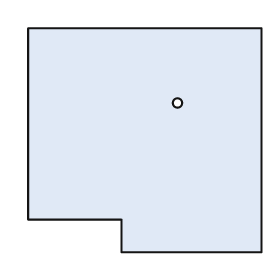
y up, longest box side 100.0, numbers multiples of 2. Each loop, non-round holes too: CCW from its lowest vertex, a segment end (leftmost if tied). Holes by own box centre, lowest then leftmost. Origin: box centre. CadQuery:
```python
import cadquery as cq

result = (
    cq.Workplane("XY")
    .moveTo(-10.0, -48.0)
    .lineTo(50.0, -48.0)
    .lineTo(50.0, 48.0)
    .lineTo(-50.0, 48.0)
    .lineTo(-50.0, -34.0)
    .lineTo(-10.0, -34.0)
    .close()
    .moveTo(14.0, 16.0)
    .circle(2.0)
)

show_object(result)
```